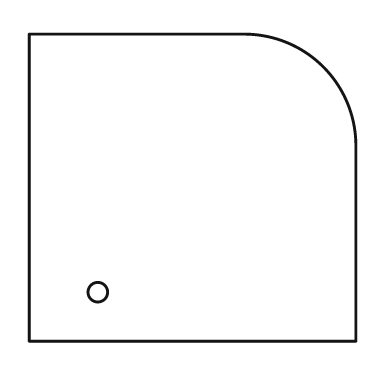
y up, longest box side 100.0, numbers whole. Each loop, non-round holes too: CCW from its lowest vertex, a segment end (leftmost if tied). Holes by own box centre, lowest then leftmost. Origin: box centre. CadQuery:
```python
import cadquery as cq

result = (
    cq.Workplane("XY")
    .moveTo(-50.0, -47.0)
    .lineTo(50.0, -47.0)
    .lineTo(50.0, 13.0)
    .threePointArc((40.0, 37.0), (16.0, 47.0))
    .lineTo(-50.0, 47.0)
    .close()
    .moveTo(-29.0, -32.0)
    .circle(3.0)
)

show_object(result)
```